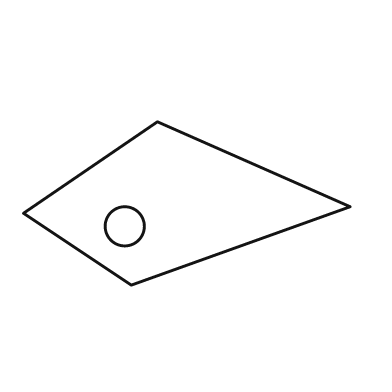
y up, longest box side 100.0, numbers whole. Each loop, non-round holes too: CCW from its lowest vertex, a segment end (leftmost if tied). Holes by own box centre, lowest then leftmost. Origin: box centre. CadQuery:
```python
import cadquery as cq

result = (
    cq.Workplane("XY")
    .moveTo(-17.0, -25.0)
    .lineTo(50.0, -1.0)
    .lineTo(-9.0, 25.0)
    .lineTo(-50.0, -3.0)
    .close()
    .moveTo(-19.0, -7.0)
    .circle(6.0)
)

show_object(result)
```